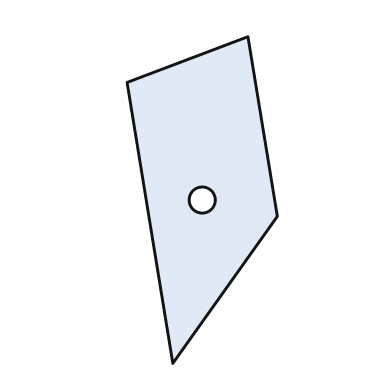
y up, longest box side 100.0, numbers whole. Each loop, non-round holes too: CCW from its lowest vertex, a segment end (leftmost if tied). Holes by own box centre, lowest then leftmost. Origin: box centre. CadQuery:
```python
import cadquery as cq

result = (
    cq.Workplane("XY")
    .moveTo(-9.0, -50.0)
    .lineTo(23.0, -5.0)
    .lineTo(14.0, 50.0)
    .lineTo(-23.0, 36.0)
    .close()
    .moveTo(0.0, 0.0)
    .circle(4.0)
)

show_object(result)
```